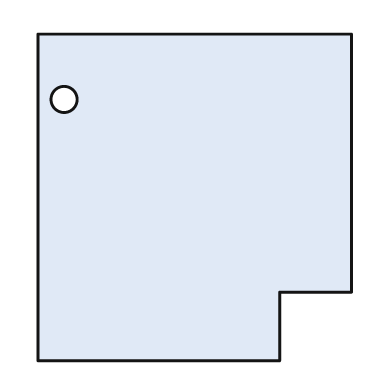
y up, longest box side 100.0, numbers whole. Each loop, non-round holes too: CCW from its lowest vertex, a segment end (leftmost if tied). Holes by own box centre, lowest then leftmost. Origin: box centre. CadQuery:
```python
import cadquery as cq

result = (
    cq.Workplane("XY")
    .moveTo(-48.0, -50.0)
    .lineTo(26.0, -50.0)
    .lineTo(26.0, -29.0)
    .lineTo(48.0, -29.0)
    .lineTo(48.0, 50.0)
    .lineTo(-48.0, 50.0)
    .close()
    .moveTo(-40.0, 30.0)
    .circle(4.0)
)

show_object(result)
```